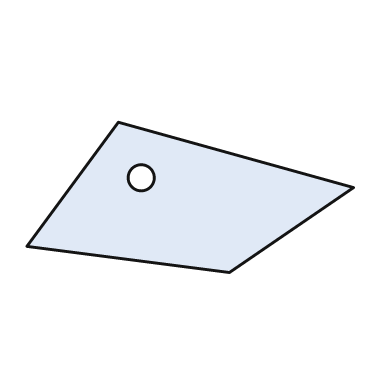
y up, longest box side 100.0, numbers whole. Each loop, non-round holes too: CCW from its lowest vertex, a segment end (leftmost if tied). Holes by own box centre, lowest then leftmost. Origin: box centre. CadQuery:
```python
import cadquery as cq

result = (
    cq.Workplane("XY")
    .moveTo(12.0, -23.0)
    .lineTo(50.0, 3.0)
    .lineTo(-22.0, 23.0)
    .lineTo(-50.0, -15.0)
    .close()
    .moveTo(-15.0, 6.0)
    .circle(4.0)
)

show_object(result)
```